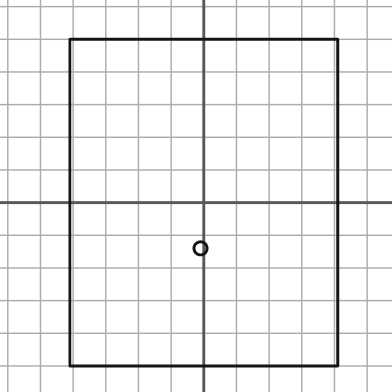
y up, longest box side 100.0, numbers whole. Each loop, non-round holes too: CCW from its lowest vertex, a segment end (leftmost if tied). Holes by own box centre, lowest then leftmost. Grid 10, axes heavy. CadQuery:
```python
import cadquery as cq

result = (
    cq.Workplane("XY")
    .moveTo(-41.0, -50.0)
    .lineTo(41.0, -50.0)
    .lineTo(41.0, 50.0)
    .lineTo(-41.0, 50.0)
    .close()
    .moveTo(-1.0, -14.0)
    .circle(2.0)
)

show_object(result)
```